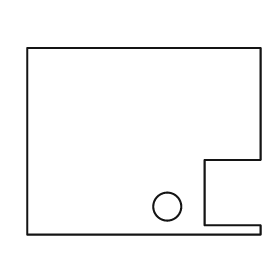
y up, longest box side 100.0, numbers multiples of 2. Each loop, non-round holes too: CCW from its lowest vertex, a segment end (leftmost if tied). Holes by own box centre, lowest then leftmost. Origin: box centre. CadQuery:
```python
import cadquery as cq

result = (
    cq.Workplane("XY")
    .moveTo(-50.0, -40.0)
    .lineTo(50.0, -40.0)
    .lineTo(50.0, -36.0)
    .lineTo(26.0, -36.0)
    .lineTo(26.0, -8.0)
    .lineTo(50.0, -8.0)
    .lineTo(50.0, 40.0)
    .lineTo(-50.0, 40.0)
    .close()
    .moveTo(10.0, -28.0)
    .circle(6.0)
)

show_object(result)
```